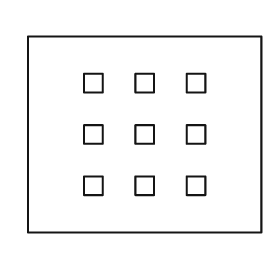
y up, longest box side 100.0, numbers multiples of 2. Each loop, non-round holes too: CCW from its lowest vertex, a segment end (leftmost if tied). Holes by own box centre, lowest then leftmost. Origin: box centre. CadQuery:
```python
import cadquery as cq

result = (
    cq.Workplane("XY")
    .moveTo(-50.0, -42.0)
    .lineTo(50.0, -42.0)
    .lineTo(50.0, 42.0)
    .lineTo(-50.0, 42.0)
    .close()
    .moveTo(-26.0, -26.0)
    .lineTo(-18.0, -26.0)
    .lineTo(-18.0, -18.0)
    .lineTo(-26.0, -18.0)
    .close()
    .moveTo(-4.0, -26.0)
    .lineTo(4.0, -26.0)
    .lineTo(4.0, -18.0)
    .lineTo(-4.0, -18.0)
    .close()
    .moveTo(18.0, -26.0)
    .lineTo(26.0, -26.0)
    .lineTo(26.0, -18.0)
    .lineTo(18.0, -18.0)
    .close()
    .moveTo(-26.0, -4.0)
    .lineTo(-18.0, -4.0)
    .lineTo(-18.0, 4.0)
    .lineTo(-26.0, 4.0)
    .close()
    .moveTo(-4.0, -4.0)
    .lineTo(4.0, -4.0)
    .lineTo(4.0, 4.0)
    .lineTo(-4.0, 4.0)
    .close()
    .moveTo(18.0, -4.0)
    .lineTo(26.0, -4.0)
    .lineTo(26.0, 4.0)
    .lineTo(18.0, 4.0)
    .close()
    .moveTo(-26.0, 18.0)
    .lineTo(-18.0, 18.0)
    .lineTo(-18.0, 26.0)
    .lineTo(-26.0, 26.0)
    .close()
    .moveTo(-4.0, 18.0)
    .lineTo(4.0, 18.0)
    .lineTo(4.0, 26.0)
    .lineTo(-4.0, 26.0)
    .close()
    .moveTo(18.0, 18.0)
    .lineTo(26.0, 18.0)
    .lineTo(26.0, 26.0)
    .lineTo(18.0, 26.0)
    .close()
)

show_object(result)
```